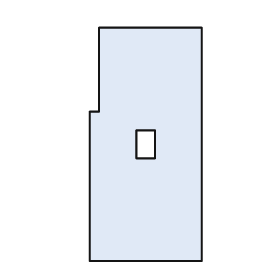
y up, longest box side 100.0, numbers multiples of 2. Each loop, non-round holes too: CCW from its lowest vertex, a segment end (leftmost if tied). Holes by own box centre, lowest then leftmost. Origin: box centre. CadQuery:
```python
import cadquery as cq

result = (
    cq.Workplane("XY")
    .moveTo(-24.0, -50.0)
    .lineTo(24.0, -50.0)
    .lineTo(24.0, 50.0)
    .lineTo(-20.0, 50.0)
    .lineTo(-20.0, 14.0)
    .lineTo(-24.0, 14.0)
    .close()
    .moveTo(-4.0, -6.0)
    .lineTo(4.0, -6.0)
    .lineTo(4.0, 6.0)
    .lineTo(-4.0, 6.0)
    .close()
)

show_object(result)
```